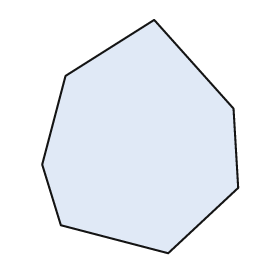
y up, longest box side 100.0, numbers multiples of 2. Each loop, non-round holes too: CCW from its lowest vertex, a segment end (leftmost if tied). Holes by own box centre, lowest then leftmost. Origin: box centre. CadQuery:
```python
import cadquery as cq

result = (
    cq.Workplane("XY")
    .moveTo(12.0, -50.0)
    .lineTo(42.0, -22.0)
    .lineTo(40.0, 12.0)
    .lineTo(6.0, 50.0)
    .lineTo(-32.0, 26.0)
    .lineTo(-42.0, -12.0)
    .lineTo(-34.0, -38.0)
    .close()
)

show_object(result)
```